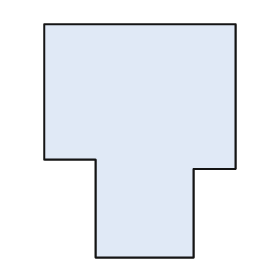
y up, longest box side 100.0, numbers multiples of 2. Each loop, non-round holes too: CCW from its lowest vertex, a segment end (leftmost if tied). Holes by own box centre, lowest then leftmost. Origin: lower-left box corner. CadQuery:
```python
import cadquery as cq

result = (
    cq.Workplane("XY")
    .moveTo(22.0, 0.0)
    .lineTo(64.0, 0.0)
    .lineTo(64.0, 38.0)
    .lineTo(82.0, 38.0)
    .lineTo(82.0, 100.0)
    .lineTo(0.0, 100.0)
    .lineTo(0.0, 42.0)
    .lineTo(22.0, 42.0)
    .close()
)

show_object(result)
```